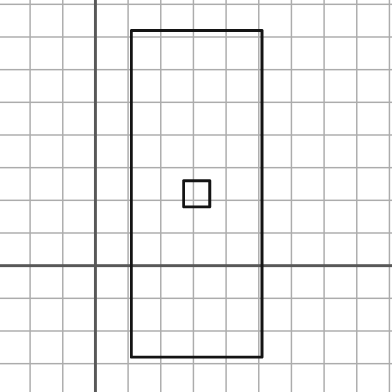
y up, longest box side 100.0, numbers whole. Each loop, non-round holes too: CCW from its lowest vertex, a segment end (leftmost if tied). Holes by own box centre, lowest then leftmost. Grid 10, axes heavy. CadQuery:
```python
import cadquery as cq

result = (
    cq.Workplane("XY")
    .moveTo(11.0, -28.0)
    .lineTo(51.0, -28.0)
    .lineTo(51.0, 72.0)
    .lineTo(11.0, 72.0)
    .close()
    .moveTo(27.0, 18.0)
    .lineTo(35.0, 18.0)
    .lineTo(35.0, 26.0)
    .lineTo(27.0, 26.0)
    .close()
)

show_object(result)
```